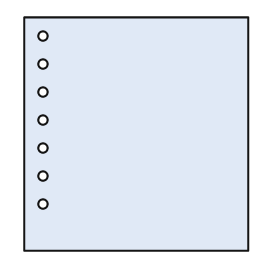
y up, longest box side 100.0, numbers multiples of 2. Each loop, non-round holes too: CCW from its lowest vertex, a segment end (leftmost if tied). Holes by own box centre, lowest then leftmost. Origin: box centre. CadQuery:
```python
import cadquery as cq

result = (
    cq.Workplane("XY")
    .moveTo(-48.0, -50.0)
    .lineTo(48.0, -50.0)
    .lineTo(48.0, 50.0)
    .lineTo(-48.0, 50.0)
    .close()
    .moveTo(-40.0, -30.0)
    .circle(2.0)
    .moveTo(-40.0, -18.0)
    .circle(2.0)
    .moveTo(-40.0, -6.0)
    .circle(2.0)
    .moveTo(-40.0, 6.0)
    .circle(2.0)
    .moveTo(-40.0, 18.0)
    .circle(2.0)
    .moveTo(-40.0, 30.0)
    .circle(2.0)
    .moveTo(-40.0, 42.0)
    .circle(2.0)
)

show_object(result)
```